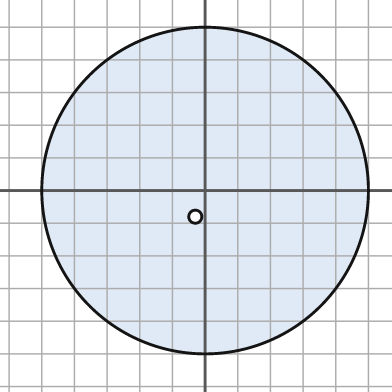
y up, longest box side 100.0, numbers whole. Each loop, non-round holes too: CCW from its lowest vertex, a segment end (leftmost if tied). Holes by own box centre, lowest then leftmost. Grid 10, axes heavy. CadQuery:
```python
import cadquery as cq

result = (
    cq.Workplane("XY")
    .moveTo(0.0, 0.0)
    .circle(50.0)
    .moveTo(-3.0, -8.0)
    .circle(2.0)
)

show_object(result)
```